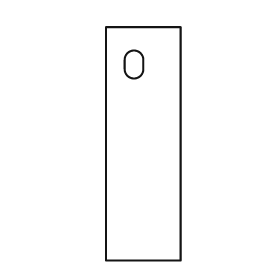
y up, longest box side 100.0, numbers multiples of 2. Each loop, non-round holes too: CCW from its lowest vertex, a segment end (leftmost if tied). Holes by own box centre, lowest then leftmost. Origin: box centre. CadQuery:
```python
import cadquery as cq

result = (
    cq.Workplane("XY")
    .moveTo(-16.0, -50.0)
    .lineTo(16.0, -50.0)
    .lineTo(16.0, 50.0)
    .lineTo(-16.0, 50.0)
    .close()
    .moveTo(-8.0, 32.0)
    .threePointArc((-4.0, 28.0), (0.0, 32.0))
    .lineTo(0.0, 36.0)
    .threePointArc((-4.0, 40.0), (-8.0, 36.0))
    .close()
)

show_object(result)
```